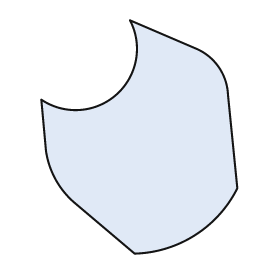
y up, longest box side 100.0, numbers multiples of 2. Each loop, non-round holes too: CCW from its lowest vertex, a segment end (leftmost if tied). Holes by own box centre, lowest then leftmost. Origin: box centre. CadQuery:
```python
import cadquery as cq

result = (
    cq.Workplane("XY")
    .moveTo(-2.0, -50.0)
    .threePointArc((24.0, -42.0), (42.0, -22.0))
    .lineTo(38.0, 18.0)
    .threePointArc((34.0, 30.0), (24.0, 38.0))
    .lineTo(-4.0, 50.0)
    .threePointArc((-10.0, 18.0), (-42.0, 16.0))
    .lineTo(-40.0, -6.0)
    .threePointArc((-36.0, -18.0), (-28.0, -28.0))
    .close()
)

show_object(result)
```